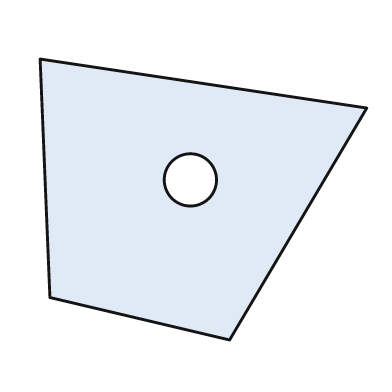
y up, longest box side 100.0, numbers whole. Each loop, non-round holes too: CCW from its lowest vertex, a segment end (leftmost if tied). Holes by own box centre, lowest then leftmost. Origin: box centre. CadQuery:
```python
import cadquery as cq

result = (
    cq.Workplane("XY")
    .moveTo(8.0, -43.0)
    .lineTo(50.0, 28.0)
    .lineTo(-50.0, 43.0)
    .lineTo(-47.0, -30.0)
    .close()
    .moveTo(-4.0, 6.0)
    .circle(8.0)
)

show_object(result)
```